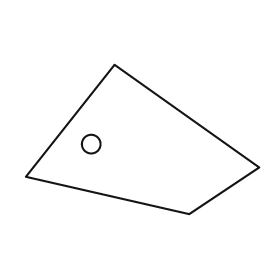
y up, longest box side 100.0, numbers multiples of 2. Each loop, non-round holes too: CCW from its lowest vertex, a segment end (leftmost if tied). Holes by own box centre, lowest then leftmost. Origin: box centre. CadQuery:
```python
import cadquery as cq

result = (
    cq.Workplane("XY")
    .moveTo(20.0, -32.0)
    .lineTo(50.0, -12.0)
    .lineTo(-12.0, 32.0)
    .lineTo(-50.0, -16.0)
    .close()
    .moveTo(-22.0, -2.0)
    .circle(4.0)
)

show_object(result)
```